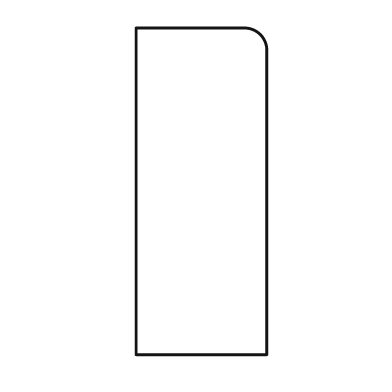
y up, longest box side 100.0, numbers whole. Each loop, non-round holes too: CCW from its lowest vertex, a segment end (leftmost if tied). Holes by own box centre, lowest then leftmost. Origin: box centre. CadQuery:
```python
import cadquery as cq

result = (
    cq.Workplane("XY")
    .moveTo(-20.0, -50.0)
    .lineTo(20.0, -50.0)
    .lineTo(20.0, 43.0)
    .threePointArc((18.0, 48.0), (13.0, 50.0))
    .lineTo(-20.0, 50.0)
    .close()
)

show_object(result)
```